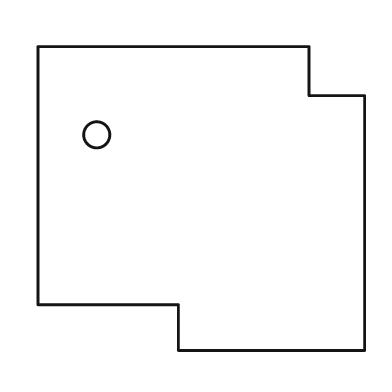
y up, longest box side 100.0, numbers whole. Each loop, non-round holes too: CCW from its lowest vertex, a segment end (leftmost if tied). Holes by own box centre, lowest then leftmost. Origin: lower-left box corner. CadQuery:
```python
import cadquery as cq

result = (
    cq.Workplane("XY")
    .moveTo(43.0, 0.0)
    .lineTo(100.0, 0.0)
    .lineTo(100.0, 78.0)
    .lineTo(83.0, 78.0)
    .lineTo(83.0, 93.0)
    .lineTo(0.0, 93.0)
    .lineTo(0.0, 14.0)
    .lineTo(43.0, 14.0)
    .close()
    .moveTo(18.0, 66.0)
    .circle(4.0)
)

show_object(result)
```